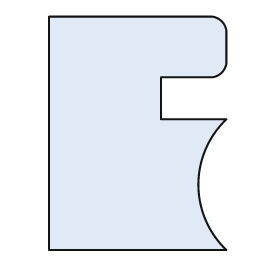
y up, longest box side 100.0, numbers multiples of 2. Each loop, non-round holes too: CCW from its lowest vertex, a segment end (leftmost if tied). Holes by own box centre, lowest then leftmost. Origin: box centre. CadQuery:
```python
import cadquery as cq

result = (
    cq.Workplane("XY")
    .moveTo(-38.0, -50.0)
    .lineTo(38.0, -50.0)
    .threePointArc((26.0, -22.0), (38.0, 6.0))
    .lineTo(10.0, 6.0)
    .lineTo(10.0, 24.0)
    .lineTo(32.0, 24.0)
    .threePointArc((36.0, 26.0), (38.0, 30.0))
    .lineTo(38.0, 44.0)
    .threePointArc((36.0, 48.0), (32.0, 50.0))
    .lineTo(-38.0, 50.0)
    .close()
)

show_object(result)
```